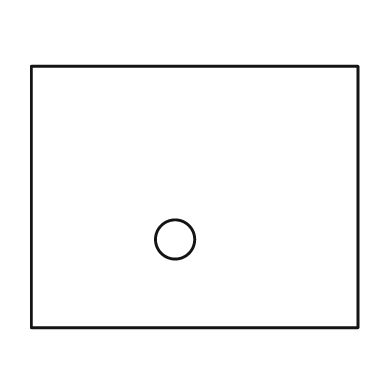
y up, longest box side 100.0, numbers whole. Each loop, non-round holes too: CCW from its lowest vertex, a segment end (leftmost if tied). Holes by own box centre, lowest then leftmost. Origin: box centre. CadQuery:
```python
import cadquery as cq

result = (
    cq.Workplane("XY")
    .moveTo(-50.0, -40.0)
    .lineTo(50.0, -40.0)
    .lineTo(50.0, 40.0)
    .lineTo(-50.0, 40.0)
    .close()
    .moveTo(-6.0, -13.0)
    .circle(6.0)
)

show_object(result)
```